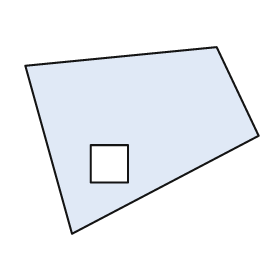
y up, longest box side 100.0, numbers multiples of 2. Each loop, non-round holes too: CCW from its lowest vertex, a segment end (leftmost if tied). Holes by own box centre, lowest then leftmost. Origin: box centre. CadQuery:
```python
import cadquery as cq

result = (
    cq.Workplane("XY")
    .moveTo(-30.0, -40.0)
    .lineTo(50.0, 2.0)
    .lineTo(32.0, 40.0)
    .lineTo(-50.0, 32.0)
    .close()
    .moveTo(-22.0, -18.0)
    .lineTo(-6.0, -18.0)
    .lineTo(-6.0, -2.0)
    .lineTo(-22.0, -2.0)
    .close()
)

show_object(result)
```